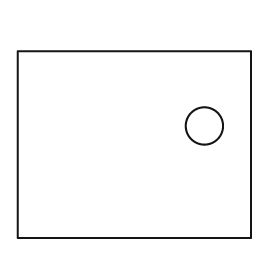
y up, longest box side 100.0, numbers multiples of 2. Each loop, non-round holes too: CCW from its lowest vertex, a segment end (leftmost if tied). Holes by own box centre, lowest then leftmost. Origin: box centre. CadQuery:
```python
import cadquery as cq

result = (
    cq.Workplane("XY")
    .moveTo(-50.0, -40.0)
    .lineTo(50.0, -40.0)
    .lineTo(50.0, 40.0)
    .lineTo(-50.0, 40.0)
    .close()
    .moveTo(30.0, 8.0)
    .circle(8.0)
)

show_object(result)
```